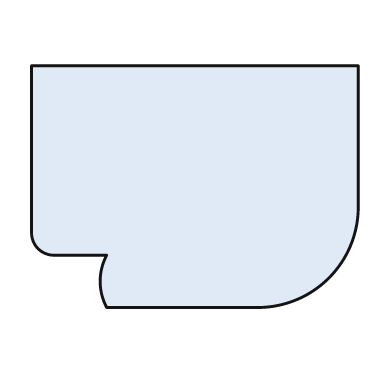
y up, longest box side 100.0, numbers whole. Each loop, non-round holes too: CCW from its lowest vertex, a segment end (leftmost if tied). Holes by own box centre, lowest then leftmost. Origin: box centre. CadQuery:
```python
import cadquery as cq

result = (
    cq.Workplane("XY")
    .moveTo(-27.0, -37.0)
    .lineTo(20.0, -37.0)
    .threePointArc((41.0, -28.0), (50.0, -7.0))
    .lineTo(50.0, 37.0)
    .lineTo(-50.0, 37.0)
    .lineTo(-50.0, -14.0)
    .threePointArc((-48.0, -19.0), (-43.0, -21.0))
    .lineTo(-27.0, -21.0)
    .threePointArc((-29.0, -29.0), (-27.0, -37.0))
    .close()
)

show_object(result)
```